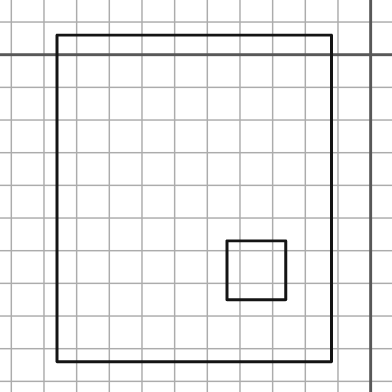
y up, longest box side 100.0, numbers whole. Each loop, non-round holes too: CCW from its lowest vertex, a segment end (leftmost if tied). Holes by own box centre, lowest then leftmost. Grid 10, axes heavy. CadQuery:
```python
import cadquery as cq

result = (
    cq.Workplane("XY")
    .moveTo(-96.0, -94.0)
    .lineTo(-12.0, -94.0)
    .lineTo(-12.0, 6.0)
    .lineTo(-96.0, 6.0)
    .close()
    .moveTo(-44.0, -75.0)
    .lineTo(-26.0, -75.0)
    .lineTo(-26.0, -57.0)
    .lineTo(-44.0, -57.0)
    .close()
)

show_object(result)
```